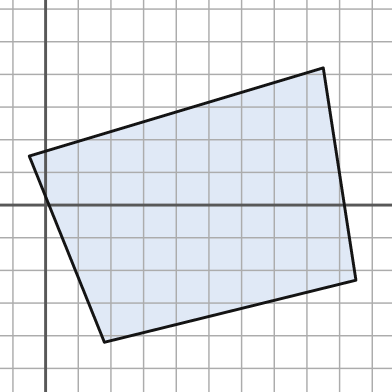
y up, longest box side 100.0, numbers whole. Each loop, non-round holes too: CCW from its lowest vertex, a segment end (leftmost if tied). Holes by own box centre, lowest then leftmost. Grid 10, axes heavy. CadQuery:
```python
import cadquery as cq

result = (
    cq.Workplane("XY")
    .moveTo(18.0, -42.0)
    .lineTo(95.0, -23.0)
    .lineTo(85.0, 42.0)
    .lineTo(-5.0, 15.0)
    .close()
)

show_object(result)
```